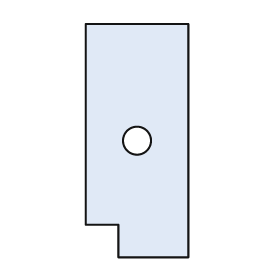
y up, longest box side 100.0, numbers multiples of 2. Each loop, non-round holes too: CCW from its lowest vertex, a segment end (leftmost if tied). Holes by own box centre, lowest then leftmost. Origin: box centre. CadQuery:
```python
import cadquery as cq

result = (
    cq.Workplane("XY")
    .moveTo(-8.0, -50.0)
    .lineTo(22.0, -50.0)
    .lineTo(22.0, 50.0)
    .lineTo(-22.0, 50.0)
    .lineTo(-22.0, -36.0)
    .lineTo(-8.0, -36.0)
    .close()
    .moveTo(0.0, 0.0)
    .circle(6.0)
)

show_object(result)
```